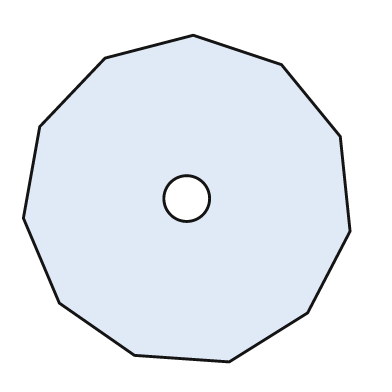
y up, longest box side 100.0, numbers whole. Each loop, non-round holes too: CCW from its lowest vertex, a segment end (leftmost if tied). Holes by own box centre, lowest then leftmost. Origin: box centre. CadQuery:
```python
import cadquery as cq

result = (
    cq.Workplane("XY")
    .moveTo(13.0, -50.0)
    .lineTo(37.0, -35.0)
    .lineTo(50.0, -10.0)
    .lineTo(47.0, 19.0)
    .lineTo(29.0, 41.0)
    .lineTo(2.0, 50.0)
    .lineTo(-25.0, 43.0)
    .lineTo(-45.0, 22.0)
    .lineTo(-50.0, -6.0)
    .lineTo(-39.0, -32.0)
    .lineTo(-16.0, -48.0)
    .close()
    .moveTo(0.0, 0.0)
    .circle(7.0)
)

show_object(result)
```